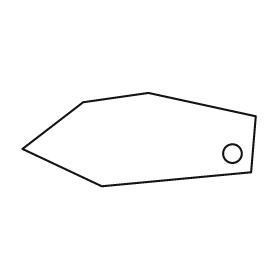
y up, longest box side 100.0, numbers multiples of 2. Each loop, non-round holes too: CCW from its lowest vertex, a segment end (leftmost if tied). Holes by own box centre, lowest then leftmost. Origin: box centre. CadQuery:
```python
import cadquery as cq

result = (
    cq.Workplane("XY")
    .moveTo(-16.0, -20.0)
    .lineTo(48.0, -14.0)
    .lineTo(50.0, 10.0)
    .lineTo(4.0, 20.0)
    .lineTo(-24.0, 16.0)
    .lineTo(-50.0, -4.0)
    .close()
    .moveTo(40.0, -6.0)
    .circle(4.0)
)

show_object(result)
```